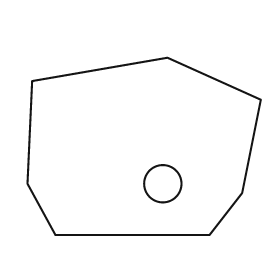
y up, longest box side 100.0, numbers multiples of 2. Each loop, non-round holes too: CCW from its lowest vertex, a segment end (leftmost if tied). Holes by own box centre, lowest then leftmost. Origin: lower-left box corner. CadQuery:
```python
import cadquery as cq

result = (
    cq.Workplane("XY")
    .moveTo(12.0, 0.0)
    .lineTo(78.0, 0.0)
    .lineTo(92.0, 18.0)
    .lineTo(100.0, 58.0)
    .lineTo(60.0, 76.0)
    .lineTo(2.0, 66.0)
    .lineTo(0.0, 22.0)
    .close()
    .moveTo(58.0, 22.0)
    .circle(8.0)
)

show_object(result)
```